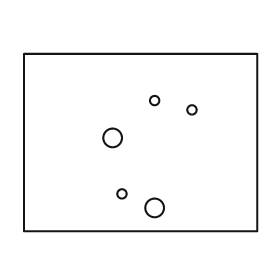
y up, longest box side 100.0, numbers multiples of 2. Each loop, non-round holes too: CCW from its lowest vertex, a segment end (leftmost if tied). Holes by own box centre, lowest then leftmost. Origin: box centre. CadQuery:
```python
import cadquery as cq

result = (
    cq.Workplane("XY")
    .moveTo(-50.0, -38.0)
    .lineTo(50.0, -38.0)
    .lineTo(50.0, 38.0)
    .lineTo(-50.0, 38.0)
    .close()
    .moveTo(6.0, -28.0)
    .circle(4.0)
    .moveTo(-8.0, -22.0)
    .circle(2.0)
    .moveTo(-12.0, 2.0)
    .circle(4.0)
    .moveTo(22.0, 14.0)
    .circle(2.0)
    .moveTo(6.0, 18.0)
    .circle(2.0)
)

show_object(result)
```